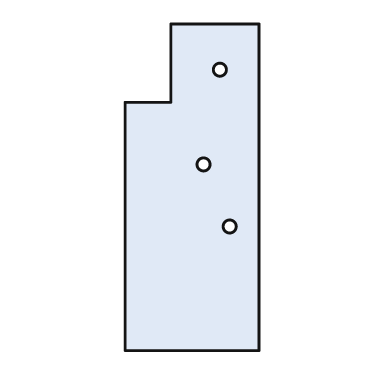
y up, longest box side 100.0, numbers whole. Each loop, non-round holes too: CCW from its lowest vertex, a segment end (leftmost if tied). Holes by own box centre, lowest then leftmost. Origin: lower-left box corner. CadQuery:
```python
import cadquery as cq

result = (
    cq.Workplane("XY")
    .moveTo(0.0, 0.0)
    .lineTo(41.0, 0.0)
    .lineTo(41.0, 100.0)
    .lineTo(14.0, 100.0)
    .lineTo(14.0, 76.0)
    .lineTo(0.0, 76.0)
    .close()
    .moveTo(32.0, 38.0)
    .circle(2.0)
    .moveTo(24.0, 57.0)
    .circle(2.0)
    .moveTo(29.0, 86.0)
    .circle(2.0)
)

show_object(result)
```